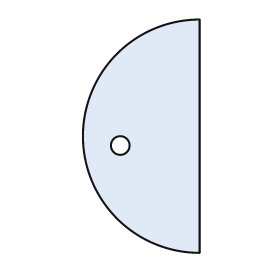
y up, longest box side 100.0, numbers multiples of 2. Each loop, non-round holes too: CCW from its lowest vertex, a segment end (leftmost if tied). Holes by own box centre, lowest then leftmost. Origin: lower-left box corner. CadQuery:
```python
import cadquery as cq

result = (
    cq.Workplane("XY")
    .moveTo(50.0, 0.0)
    .lineTo(50.0, 100.0)
    .threePointArc((0.0, 50.0), (50.0, 0.0))
    .close()
    .moveTo(16.0, 46.0)
    .circle(4.0)
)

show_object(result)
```